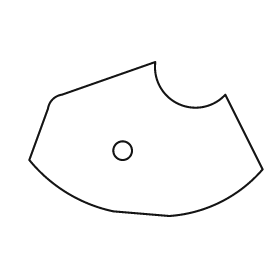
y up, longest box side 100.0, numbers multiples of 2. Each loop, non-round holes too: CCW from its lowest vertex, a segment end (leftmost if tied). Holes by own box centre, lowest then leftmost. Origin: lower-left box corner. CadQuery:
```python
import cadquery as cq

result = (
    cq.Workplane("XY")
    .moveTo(60.0, 0.0)
    .threePointArc((82.0, 6.0), (100.0, 20.0))
    .lineTo(84.0, 52.0)
    .threePointArc((64.0, 48.0), (54.0, 66.0))
    .lineTo(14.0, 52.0)
    .threePointArc((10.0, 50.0), (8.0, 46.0))
    .lineTo(0.0, 24.0)
    .threePointArc((16.0, 10.0), (36.0, 2.0))
    .close()
    .moveTo(40.0, 28.0)
    .circle(4.0)
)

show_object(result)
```